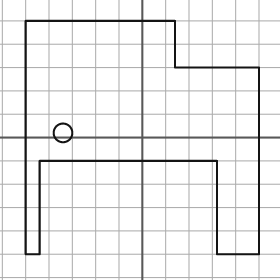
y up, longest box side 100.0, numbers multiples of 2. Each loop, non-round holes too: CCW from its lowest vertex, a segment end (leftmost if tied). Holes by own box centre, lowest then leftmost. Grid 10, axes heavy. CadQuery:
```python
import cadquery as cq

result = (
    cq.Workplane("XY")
    .moveTo(-50.0, -50.0)
    .lineTo(-44.0, -50.0)
    .lineTo(-44.0, -10.0)
    .lineTo(32.0, -10.0)
    .lineTo(32.0, -50.0)
    .lineTo(50.0, -50.0)
    .lineTo(50.0, 30.0)
    .lineTo(14.0, 30.0)
    .lineTo(14.0, 50.0)
    .lineTo(-50.0, 50.0)
    .close()
    .moveTo(-34.0, 2.0)
    .circle(4.0)
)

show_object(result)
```